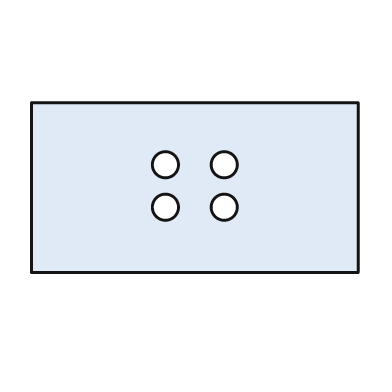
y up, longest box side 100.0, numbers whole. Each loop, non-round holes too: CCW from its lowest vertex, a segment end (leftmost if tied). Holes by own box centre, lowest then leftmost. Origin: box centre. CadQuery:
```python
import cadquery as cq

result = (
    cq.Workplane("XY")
    .moveTo(-50.0, -26.0)
    .lineTo(50.0, -26.0)
    .lineTo(50.0, 26.0)
    .lineTo(-50.0, 26.0)
    .close()
    .moveTo(-9.0, -6.0)
    .circle(4.0)
    .moveTo(9.0, -6.0)
    .circle(4.0)
    .moveTo(-9.0, 7.0)
    .circle(4.0)
    .moveTo(9.0, 7.0)
    .circle(4.0)
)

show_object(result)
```